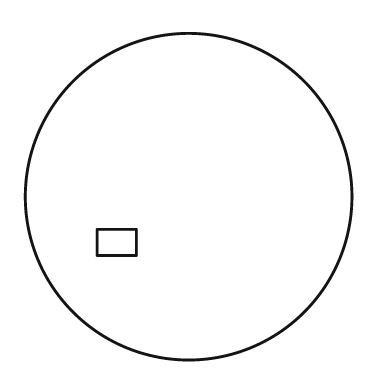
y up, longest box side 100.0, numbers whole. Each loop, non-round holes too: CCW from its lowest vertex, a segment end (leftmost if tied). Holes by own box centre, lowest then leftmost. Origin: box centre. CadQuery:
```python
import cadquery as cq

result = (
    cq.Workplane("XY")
    .moveTo(0.0, 0.0)
    .circle(50.0)
    .moveTo(-28.0, -18.0)
    .lineTo(-16.0, -18.0)
    .lineTo(-16.0, -10.0)
    .lineTo(-28.0, -10.0)
    .close()
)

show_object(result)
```